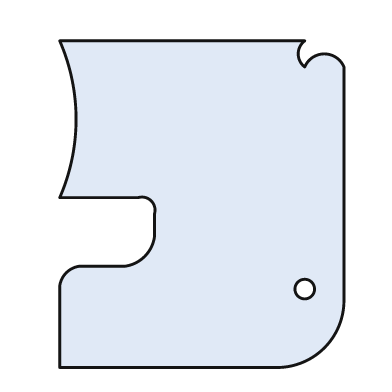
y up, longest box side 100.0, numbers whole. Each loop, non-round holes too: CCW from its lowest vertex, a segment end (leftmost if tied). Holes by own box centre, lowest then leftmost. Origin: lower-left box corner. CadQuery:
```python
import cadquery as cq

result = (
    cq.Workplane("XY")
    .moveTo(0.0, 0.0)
    .lineTo(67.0, 0.0)
    .threePointArc((81.0, 6.0), (87.0, 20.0))
    .lineTo(87.0, 92.0)
    .threePointArc((81.0, 96.0), (75.0, 92.0))
    .threePointArc((73.0, 96.0), (75.0, 100.0))
    .lineTo(0.0, 100.0)
    .threePointArc((5.0, 76.0), (0.0, 52.0))
    .lineTo(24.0, 52.0)
    .threePointArc((28.0, 51.0), (29.0, 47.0))
    .lineTo(29.0, 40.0)
    .threePointArc((26.0, 34.0), (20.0, 31.0))
    .lineTo(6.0, 31.0)
    .threePointArc((2.0, 29.0), (0.0, 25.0))
    .close()
    .moveTo(75.0, 24.0)
    .circle(3.0)
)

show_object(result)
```